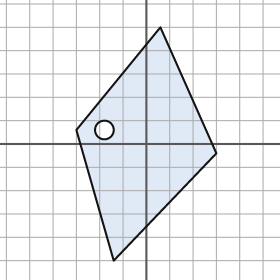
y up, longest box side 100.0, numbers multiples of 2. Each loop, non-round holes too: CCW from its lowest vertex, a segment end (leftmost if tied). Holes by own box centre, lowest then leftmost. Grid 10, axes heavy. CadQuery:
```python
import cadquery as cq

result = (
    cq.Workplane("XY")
    .moveTo(-14.0, -50.0)
    .lineTo(30.0, -4.0)
    .lineTo(6.0, 50.0)
    .lineTo(-30.0, 6.0)
    .close()
    .moveTo(-18.0, 6.0)
    .circle(4.0)
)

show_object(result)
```